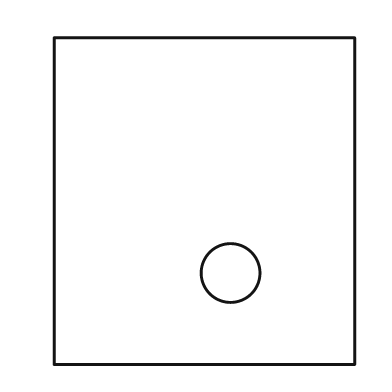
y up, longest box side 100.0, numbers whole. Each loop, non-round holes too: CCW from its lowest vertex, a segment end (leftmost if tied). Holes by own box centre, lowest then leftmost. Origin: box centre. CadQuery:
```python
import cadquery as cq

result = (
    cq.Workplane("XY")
    .moveTo(-46.0, -50.0)
    .lineTo(46.0, -50.0)
    .lineTo(46.0, 50.0)
    .lineTo(-46.0, 50.0)
    .close()
    .moveTo(8.0, -22.0)
    .circle(9.0)
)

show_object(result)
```